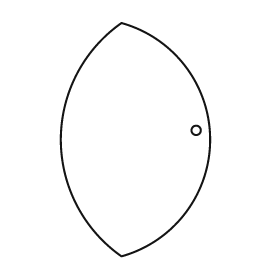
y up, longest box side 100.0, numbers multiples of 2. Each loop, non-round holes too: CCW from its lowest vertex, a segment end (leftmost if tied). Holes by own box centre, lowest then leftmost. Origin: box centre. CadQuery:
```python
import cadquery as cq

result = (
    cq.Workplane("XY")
    .moveTo(-6.0, -50.0)
    .threePointArc((32.0, 0.0), (-6.0, 50.0))
    .threePointArc((-32.0, 0.0), (-6.0, -50.0))
    .close()
    .moveTo(26.0, 4.0)
    .circle(2.0)
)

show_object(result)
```